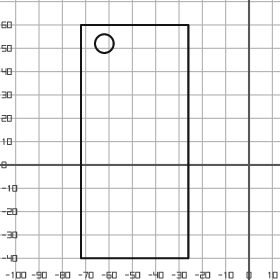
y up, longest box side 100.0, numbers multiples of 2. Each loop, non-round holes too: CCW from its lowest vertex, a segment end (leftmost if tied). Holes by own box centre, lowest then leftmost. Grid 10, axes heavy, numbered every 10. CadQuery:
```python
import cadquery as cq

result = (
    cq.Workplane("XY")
    .moveTo(-72.0, -40.0)
    .lineTo(-26.0, -40.0)
    .lineTo(-26.0, 60.0)
    .lineTo(-72.0, 60.0)
    .close()
    .moveTo(-62.0, 52.0)
    .circle(4.0)
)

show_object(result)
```